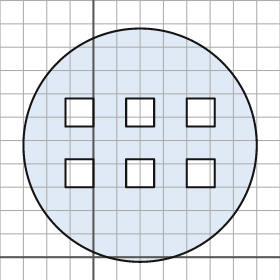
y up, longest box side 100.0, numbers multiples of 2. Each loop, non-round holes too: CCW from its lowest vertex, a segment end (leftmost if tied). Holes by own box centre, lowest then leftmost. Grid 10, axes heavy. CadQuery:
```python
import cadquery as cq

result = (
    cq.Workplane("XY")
    .moveTo(20.0, 48.0)
    .circle(50.0)
    .moveTo(-12.0, 30.0)
    .lineTo(0.0, 30.0)
    .lineTo(0.0, 42.0)
    .lineTo(-12.0, 42.0)
    .close()
    .moveTo(14.0, 30.0)
    .lineTo(26.0, 30.0)
    .lineTo(26.0, 42.0)
    .lineTo(14.0, 42.0)
    .close()
    .moveTo(40.0, 30.0)
    .lineTo(52.0, 30.0)
    .lineTo(52.0, 42.0)
    .lineTo(40.0, 42.0)
    .close()
    .moveTo(-12.0, 56.0)
    .lineTo(0.0, 56.0)
    .lineTo(0.0, 68.0)
    .lineTo(-12.0, 68.0)
    .close()
    .moveTo(14.0, 56.0)
    .lineTo(26.0, 56.0)
    .lineTo(26.0, 68.0)
    .lineTo(14.0, 68.0)
    .close()
    .moveTo(40.0, 56.0)
    .lineTo(52.0, 56.0)
    .lineTo(52.0, 68.0)
    .lineTo(40.0, 68.0)
    .close()
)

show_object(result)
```